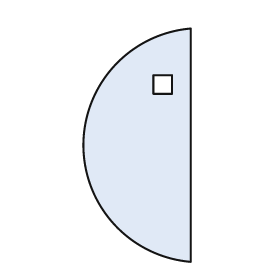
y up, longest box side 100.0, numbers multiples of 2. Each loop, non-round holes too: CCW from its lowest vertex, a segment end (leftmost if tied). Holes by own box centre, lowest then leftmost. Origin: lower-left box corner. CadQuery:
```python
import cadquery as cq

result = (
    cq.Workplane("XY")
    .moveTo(46.0, 0.0)
    .lineTo(46.0, 100.0)
    .threePointArc((0.0, 50.0), (46.0, 0.0))
    .close()
    .moveTo(30.0, 72.0)
    .lineTo(38.0, 72.0)
    .lineTo(38.0, 80.0)
    .lineTo(30.0, 80.0)
    .close()
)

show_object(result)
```